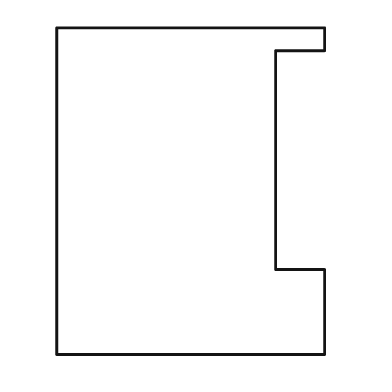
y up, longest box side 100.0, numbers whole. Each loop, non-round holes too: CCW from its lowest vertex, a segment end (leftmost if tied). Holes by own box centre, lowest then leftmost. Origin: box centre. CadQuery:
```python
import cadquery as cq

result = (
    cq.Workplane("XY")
    .moveTo(-41.0, -50.0)
    .lineTo(41.0, -50.0)
    .lineTo(41.0, -24.0)
    .lineTo(26.0, -24.0)
    .lineTo(26.0, 43.0)
    .lineTo(41.0, 43.0)
    .lineTo(41.0, 50.0)
    .lineTo(-41.0, 50.0)
    .close()
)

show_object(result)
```